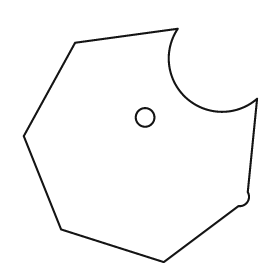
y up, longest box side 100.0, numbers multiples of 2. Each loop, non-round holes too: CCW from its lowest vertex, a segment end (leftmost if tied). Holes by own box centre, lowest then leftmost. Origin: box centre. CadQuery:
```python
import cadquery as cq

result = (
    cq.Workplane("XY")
    .moveTo(10.0, -50.0)
    .lineTo(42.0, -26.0)
    .threePointArc((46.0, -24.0), (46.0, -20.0))
    .lineTo(50.0, 20.0)
    .threePointArc((20.0, 20.0), (16.0, 50.0))
    .lineTo(-28.0, 44.0)
    .lineTo(-50.0, 4.0)
    .lineTo(-34.0, -36.0)
    .close()
    .moveTo(2.0, 12.0)
    .circle(4.0)
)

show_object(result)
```